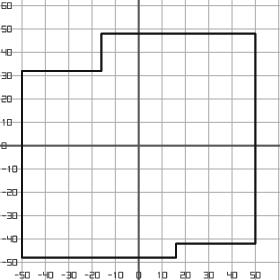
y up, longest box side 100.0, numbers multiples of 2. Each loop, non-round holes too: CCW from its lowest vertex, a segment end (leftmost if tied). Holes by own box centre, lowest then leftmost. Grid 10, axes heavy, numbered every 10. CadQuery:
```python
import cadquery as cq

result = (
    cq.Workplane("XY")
    .moveTo(-50.0, -48.0)
    .lineTo(16.0, -48.0)
    .lineTo(16.0, -42.0)
    .lineTo(50.0, -42.0)
    .lineTo(50.0, 48.0)
    .lineTo(-16.0, 48.0)
    .lineTo(-16.0, 32.0)
    .lineTo(-50.0, 32.0)
    .close()
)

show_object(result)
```